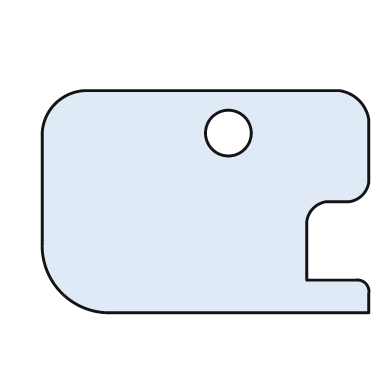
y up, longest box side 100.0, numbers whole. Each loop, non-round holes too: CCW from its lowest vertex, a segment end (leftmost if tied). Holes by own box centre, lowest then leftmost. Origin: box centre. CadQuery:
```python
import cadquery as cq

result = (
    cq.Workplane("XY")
    .moveTo(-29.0, -34.0)
    .lineTo(50.0, -34.0)
    .lineTo(50.0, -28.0)
    .threePointArc((49.0, -25.0), (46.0, -24.0))
    .lineTo(31.0, -24.0)
    .lineTo(31.0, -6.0)
    .threePointArc((33.0, -2.0), (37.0, 0.0))
    .lineTo(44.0, 0.0)
    .threePointArc((48.0, 2.0), (50.0, 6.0))
    .lineTo(50.0, 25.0)
    .threePointArc((47.0, 31.0), (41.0, 34.0))
    .lineTo(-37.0, 34.0)
    .threePointArc((-46.0, 30.0), (-50.0, 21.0))
    .lineTo(-50.0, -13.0)
    .threePointArc((-44.0, -28.0), (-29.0, -34.0))
    .close()
    .moveTo(7.0, 21.0)
    .circle(7.0)
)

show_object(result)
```